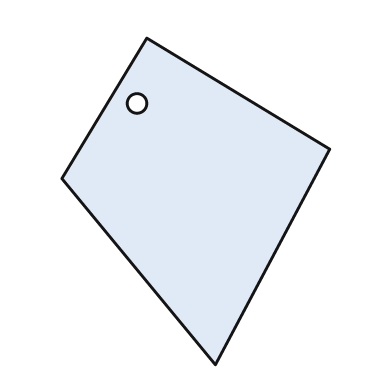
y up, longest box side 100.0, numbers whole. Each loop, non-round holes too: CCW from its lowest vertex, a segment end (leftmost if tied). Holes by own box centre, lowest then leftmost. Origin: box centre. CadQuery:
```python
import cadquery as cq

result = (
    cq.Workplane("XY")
    .moveTo(6.0, -50.0)
    .lineTo(41.0, 16.0)
    .lineTo(-15.0, 50.0)
    .lineTo(-41.0, 7.0)
    .close()
    .moveTo(-18.0, 30.0)
    .circle(3.0)
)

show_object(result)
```